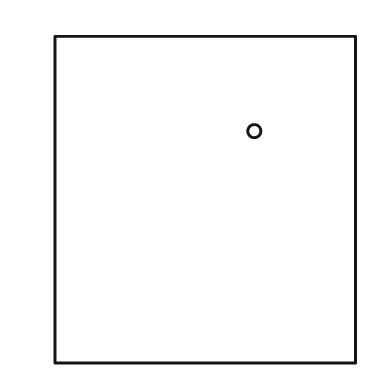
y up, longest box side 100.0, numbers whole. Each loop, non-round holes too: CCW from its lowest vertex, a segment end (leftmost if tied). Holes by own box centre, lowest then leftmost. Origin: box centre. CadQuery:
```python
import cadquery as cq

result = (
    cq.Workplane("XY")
    .moveTo(-46.0, -50.0)
    .lineTo(46.0, -50.0)
    .lineTo(46.0, 50.0)
    .lineTo(-46.0, 50.0)
    .close()
    .moveTo(15.0, 21.0)
    .circle(2.0)
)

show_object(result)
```